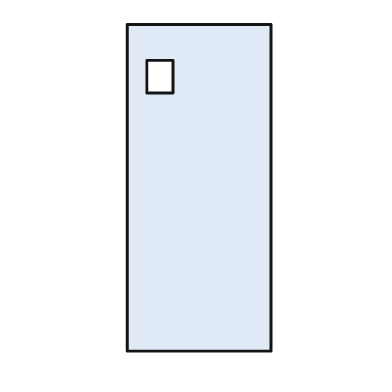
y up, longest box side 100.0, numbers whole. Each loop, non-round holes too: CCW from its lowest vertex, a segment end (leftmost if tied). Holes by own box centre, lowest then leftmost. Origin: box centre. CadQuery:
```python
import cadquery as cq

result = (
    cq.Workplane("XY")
    .moveTo(-22.0, -50.0)
    .lineTo(22.0, -50.0)
    .lineTo(22.0, 50.0)
    .lineTo(-22.0, 50.0)
    .close()
    .moveTo(-16.0, 29.0)
    .lineTo(-8.0, 29.0)
    .lineTo(-8.0, 39.0)
    .lineTo(-16.0, 39.0)
    .close()
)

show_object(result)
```